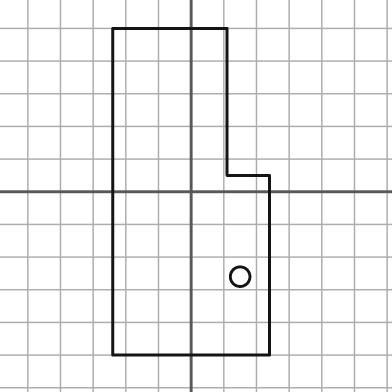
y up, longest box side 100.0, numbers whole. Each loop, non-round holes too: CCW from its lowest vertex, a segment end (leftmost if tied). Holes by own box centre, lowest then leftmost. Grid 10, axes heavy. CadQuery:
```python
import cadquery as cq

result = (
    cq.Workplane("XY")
    .moveTo(-24.0, -50.0)
    .lineTo(24.0, -50.0)
    .lineTo(24.0, 5.0)
    .lineTo(11.0, 5.0)
    .lineTo(11.0, 50.0)
    .lineTo(-24.0, 50.0)
    .close()
    .moveTo(15.0, -26.0)
    .circle(3.0)
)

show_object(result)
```